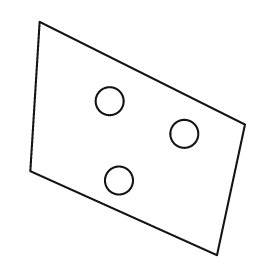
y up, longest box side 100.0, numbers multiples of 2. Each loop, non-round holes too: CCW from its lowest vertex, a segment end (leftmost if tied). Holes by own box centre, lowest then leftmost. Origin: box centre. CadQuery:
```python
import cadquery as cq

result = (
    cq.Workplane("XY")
    .moveTo(34.0, -50.0)
    .lineTo(46.0, 6.0)
    .lineTo(-42.0, 50.0)
    .lineTo(-46.0, -14.0)
    .close()
    .moveTo(-8.0, -18.0)
    .circle(6.0)
    .moveTo(20.0, 2.0)
    .circle(6.0)
    .moveTo(-12.0, 16.0)
    .circle(6.0)
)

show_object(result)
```